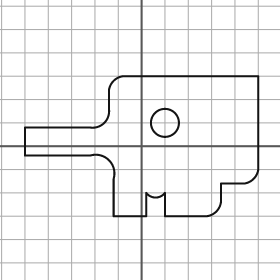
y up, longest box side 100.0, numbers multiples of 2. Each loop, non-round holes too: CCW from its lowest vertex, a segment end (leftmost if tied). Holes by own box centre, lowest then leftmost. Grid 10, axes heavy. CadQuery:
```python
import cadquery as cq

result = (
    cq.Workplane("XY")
    .moveTo(-12.0, -30.0)
    .lineTo(2.0, -30.0)
    .lineTo(2.0, -20.0)
    .threePointArc((6.0, -22.0), (10.0, -20.0))
    .lineTo(10.0, -30.0)
    .lineTo(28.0, -30.0)
    .threePointArc((32.0, -28.0), (34.0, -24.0))
    .lineTo(34.0, -16.0)
    .lineTo(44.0, -16.0)
    .threePointArc((48.0, -14.0), (50.0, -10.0))
    .lineTo(50.0, 30.0)
    .lineTo(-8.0, 30.0)
    .threePointArc((-12.0, 28.0), (-14.0, 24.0))
    .lineTo(-14.0, 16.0)
    .threePointArc((-16.0, 10.0), (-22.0, 8.0))
    .lineTo(-50.0, 8.0)
    .lineTo(-50.0, -4.0)
    .lineTo(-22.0, -4.0)
    .threePointArc((-14.0, -6.0), (-12.0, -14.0))
    .close()
    .moveTo(10.0, 10.0)
    .circle(6.0)
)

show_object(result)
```